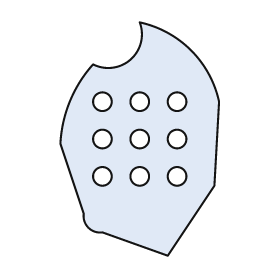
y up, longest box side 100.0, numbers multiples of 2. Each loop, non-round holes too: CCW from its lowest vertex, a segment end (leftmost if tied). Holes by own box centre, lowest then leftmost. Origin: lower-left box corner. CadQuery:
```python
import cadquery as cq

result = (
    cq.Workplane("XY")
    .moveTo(46.0, 0.0)
    .lineTo(66.0, 30.0)
    .lineTo(68.0, 66.0)
    .threePointArc((56.0, 88.0), (34.0, 100.0))
    .threePointArc((30.0, 84.0), (14.0, 82.0))
    .threePointArc((4.0, 66.0), (0.0, 48.0))
    .lineTo(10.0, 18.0)
    .threePointArc((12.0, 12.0), (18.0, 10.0))
    .close()
    .moveTo(18.0, 34.0)
    .circle(4.0)
    .moveTo(34.0, 34.0)
    .circle(4.0)
    .moveTo(50.0, 34.0)
    .circle(4.0)
    .moveTo(18.0, 50.0)
    .circle(4.0)
    .moveTo(34.0, 50.0)
    .circle(4.0)
    .moveTo(50.0, 50.0)
    .circle(4.0)
    .moveTo(18.0, 66.0)
    .circle(4.0)
    .moveTo(34.0, 66.0)
    .circle(4.0)
    .moveTo(50.0, 66.0)
    .circle(4.0)
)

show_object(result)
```